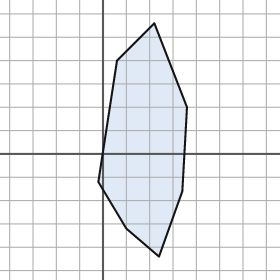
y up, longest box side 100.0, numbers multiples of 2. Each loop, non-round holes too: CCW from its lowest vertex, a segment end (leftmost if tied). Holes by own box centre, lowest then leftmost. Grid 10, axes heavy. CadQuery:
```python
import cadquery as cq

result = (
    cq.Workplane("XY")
    .moveTo(24.0, -44.0)
    .lineTo(34.0, -16.0)
    .lineTo(36.0, 20.0)
    .lineTo(22.0, 56.0)
    .lineTo(6.0, 40.0)
    .lineTo(-2.0, -12.0)
    .lineTo(10.0, -32.0)
    .close()
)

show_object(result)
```